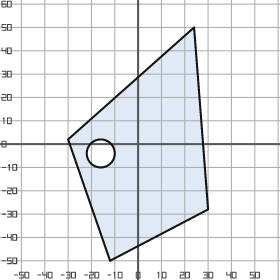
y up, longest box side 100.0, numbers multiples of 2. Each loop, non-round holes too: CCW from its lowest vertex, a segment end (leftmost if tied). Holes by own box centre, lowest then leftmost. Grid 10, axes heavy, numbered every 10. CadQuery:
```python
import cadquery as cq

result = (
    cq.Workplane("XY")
    .moveTo(-12.0, -50.0)
    .lineTo(30.0, -28.0)
    .lineTo(24.0, 50.0)
    .lineTo(-30.0, 2.0)
    .close()
    .moveTo(-16.0, -4.0)
    .circle(6.0)
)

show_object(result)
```